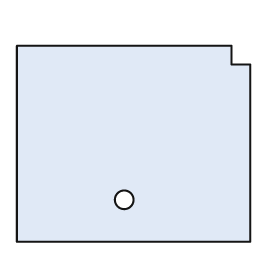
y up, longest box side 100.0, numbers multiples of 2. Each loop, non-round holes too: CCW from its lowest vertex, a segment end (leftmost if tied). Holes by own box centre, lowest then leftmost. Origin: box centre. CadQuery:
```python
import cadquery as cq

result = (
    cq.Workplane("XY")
    .moveTo(-50.0, -42.0)
    .lineTo(50.0, -42.0)
    .lineTo(50.0, 34.0)
    .lineTo(42.0, 34.0)
    .lineTo(42.0, 42.0)
    .lineTo(-50.0, 42.0)
    .close()
    .moveTo(-4.0, -24.0)
    .circle(4.0)
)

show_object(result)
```